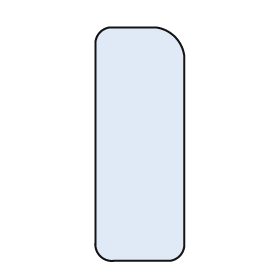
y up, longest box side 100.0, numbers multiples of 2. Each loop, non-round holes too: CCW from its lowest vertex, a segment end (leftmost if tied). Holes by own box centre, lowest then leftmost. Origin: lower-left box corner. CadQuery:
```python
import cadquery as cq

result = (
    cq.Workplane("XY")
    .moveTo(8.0, 0.0)
    .lineTo(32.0, 0.0)
    .threePointArc((36.0, 2.0), (38.0, 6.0))
    .lineTo(38.0, 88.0)
    .threePointArc((34.0, 96.0), (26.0, 100.0))
    .lineTo(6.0, 100.0)
    .threePointArc((2.0, 98.0), (0.0, 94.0))
    .lineTo(0.0, 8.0)
    .threePointArc((2.0, 2.0), (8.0, 0.0))
    .close()
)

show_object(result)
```